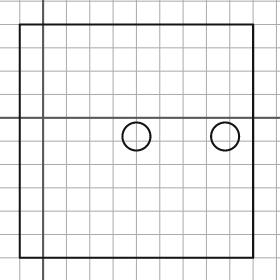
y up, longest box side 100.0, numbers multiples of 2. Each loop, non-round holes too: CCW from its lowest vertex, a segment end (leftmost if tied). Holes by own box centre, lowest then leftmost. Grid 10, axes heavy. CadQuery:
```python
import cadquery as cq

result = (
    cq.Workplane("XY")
    .moveTo(-10.0, -60.0)
    .lineTo(90.0, -60.0)
    .lineTo(90.0, 40.0)
    .lineTo(-10.0, 40.0)
    .close()
    .moveTo(40.0, -8.0)
    .circle(6.0)
    .moveTo(78.0, -8.0)
    .circle(6.0)
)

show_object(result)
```